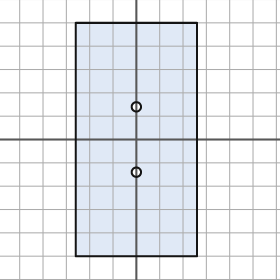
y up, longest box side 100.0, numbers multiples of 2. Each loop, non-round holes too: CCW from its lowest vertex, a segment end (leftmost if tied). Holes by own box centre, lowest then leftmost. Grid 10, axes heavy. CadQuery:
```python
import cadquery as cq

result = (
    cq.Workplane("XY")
    .moveTo(-26.0, -50.0)
    .lineTo(26.0, -50.0)
    .lineTo(26.0, 50.0)
    .lineTo(-26.0, 50.0)
    .close()
    .moveTo(0.0, -14.0)
    .circle(2.0)
    .moveTo(0.0, 14.0)
    .circle(2.0)
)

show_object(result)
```